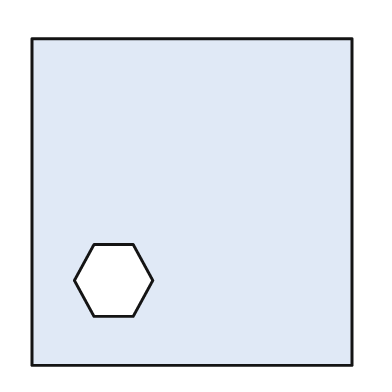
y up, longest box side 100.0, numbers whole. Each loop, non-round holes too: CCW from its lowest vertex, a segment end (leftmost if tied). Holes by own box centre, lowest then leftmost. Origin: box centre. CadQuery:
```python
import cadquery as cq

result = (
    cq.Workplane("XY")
    .moveTo(-49.0, -50.0)
    .lineTo(49.0, -50.0)
    .lineTo(49.0, 50.0)
    .lineTo(-49.0, 50.0)
    .close()
    .moveTo(-30.0, -35.0)
    .lineTo(-18.0, -35.0)
    .lineTo(-12.0, -24.0)
    .lineTo(-18.0, -13.0)
    .lineTo(-30.0, -13.0)
    .lineTo(-36.0, -24.0)
    .close()
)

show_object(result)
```